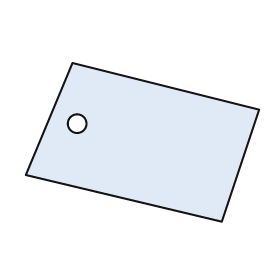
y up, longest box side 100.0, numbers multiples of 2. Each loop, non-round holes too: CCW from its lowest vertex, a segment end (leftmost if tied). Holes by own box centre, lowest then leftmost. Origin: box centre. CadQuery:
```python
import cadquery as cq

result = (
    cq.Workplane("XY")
    .moveTo(34.0, -34.0)
    .lineTo(50.0, 14.0)
    .lineTo(-30.0, 34.0)
    .lineTo(-50.0, -14.0)
    .close()
    .moveTo(-28.0, 8.0)
    .circle(4.0)
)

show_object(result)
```